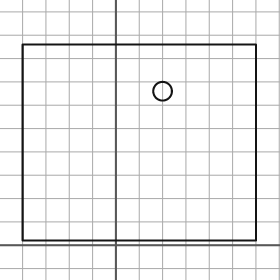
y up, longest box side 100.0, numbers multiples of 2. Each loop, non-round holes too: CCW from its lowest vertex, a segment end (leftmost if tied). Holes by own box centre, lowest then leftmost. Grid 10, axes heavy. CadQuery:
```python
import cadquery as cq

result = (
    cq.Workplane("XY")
    .moveTo(-40.0, 2.0)
    .lineTo(60.0, 2.0)
    .lineTo(60.0, 86.0)
    .lineTo(-40.0, 86.0)
    .close()
    .moveTo(20.0, 66.0)
    .circle(4.0)
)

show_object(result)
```